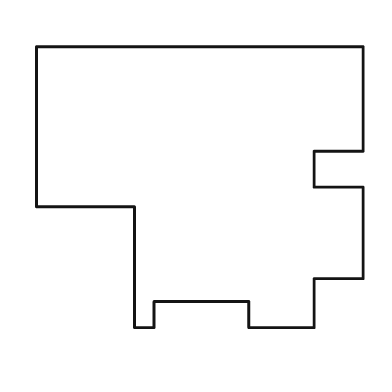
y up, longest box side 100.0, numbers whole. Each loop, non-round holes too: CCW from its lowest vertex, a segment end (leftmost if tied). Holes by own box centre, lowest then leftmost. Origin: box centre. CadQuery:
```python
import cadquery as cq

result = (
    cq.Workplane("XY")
    .moveTo(-20.0, -43.0)
    .lineTo(-14.0, -43.0)
    .lineTo(-14.0, -35.0)
    .lineTo(15.0, -35.0)
    .lineTo(15.0, -43.0)
    .lineTo(35.0, -43.0)
    .lineTo(35.0, -28.0)
    .lineTo(50.0, -28.0)
    .lineTo(50.0, 0.0)
    .lineTo(35.0, 0.0)
    .lineTo(35.0, 11.0)
    .lineTo(50.0, 11.0)
    .lineTo(50.0, 43.0)
    .lineTo(-50.0, 43.0)
    .lineTo(-50.0, -6.0)
    .lineTo(-20.0, -6.0)
    .close()
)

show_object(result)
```